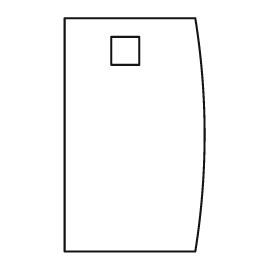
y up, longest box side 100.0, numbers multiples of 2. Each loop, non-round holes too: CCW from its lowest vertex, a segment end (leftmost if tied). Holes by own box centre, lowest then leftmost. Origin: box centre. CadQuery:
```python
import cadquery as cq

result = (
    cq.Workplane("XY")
    .moveTo(-30.0, -50.0)
    .lineTo(26.0, -50.0)
    .threePointArc((30.0, 0.0), (26.0, 50.0))
    .lineTo(-30.0, 50.0)
    .close()
    .moveTo(-10.0, 30.0)
    .lineTo(2.0, 30.0)
    .lineTo(2.0, 42.0)
    .lineTo(-10.0, 42.0)
    .close()
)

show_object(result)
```